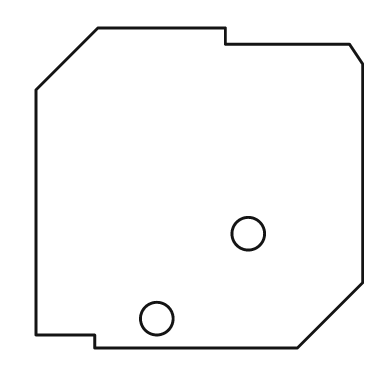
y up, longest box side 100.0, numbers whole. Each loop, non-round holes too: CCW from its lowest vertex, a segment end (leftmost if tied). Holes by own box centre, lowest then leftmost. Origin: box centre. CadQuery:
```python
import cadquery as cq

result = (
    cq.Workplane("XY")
    .moveTo(-32.0, -49.0)
    .lineTo(30.0, -49.0)
    .lineTo(50.0, -29.0)
    .lineTo(50.0, 38.0)
    .lineTo(46.0, 44.0)
    .lineTo(8.0, 44.0)
    .lineTo(8.0, 49.0)
    .lineTo(-31.0, 49.0)
    .lineTo(-50.0, 30.0)
    .lineTo(-50.0, -45.0)
    .lineTo(-32.0, -45.0)
    .close()
    .moveTo(-13.0, -40.0)
    .circle(5.0)
    .moveTo(15.0, -14.0)
    .circle(5.0)
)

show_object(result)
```